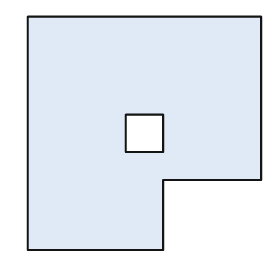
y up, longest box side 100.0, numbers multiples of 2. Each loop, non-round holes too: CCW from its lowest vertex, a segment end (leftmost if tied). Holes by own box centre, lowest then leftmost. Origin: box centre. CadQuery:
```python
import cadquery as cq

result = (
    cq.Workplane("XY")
    .moveTo(-50.0, -50.0)
    .lineTo(8.0, -50.0)
    .lineTo(8.0, -20.0)
    .lineTo(50.0, -20.0)
    .lineTo(50.0, 50.0)
    .lineTo(-50.0, 50.0)
    .close()
    .moveTo(-8.0, -8.0)
    .lineTo(8.0, -8.0)
    .lineTo(8.0, 8.0)
    .lineTo(-8.0, 8.0)
    .close()
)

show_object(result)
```